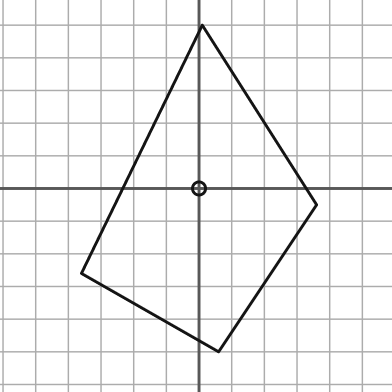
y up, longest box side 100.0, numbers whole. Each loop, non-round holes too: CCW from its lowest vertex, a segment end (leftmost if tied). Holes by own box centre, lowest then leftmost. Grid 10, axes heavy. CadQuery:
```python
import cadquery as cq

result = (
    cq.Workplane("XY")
    .moveTo(6.0, -50.0)
    .lineTo(36.0, -5.0)
    .lineTo(1.0, 50.0)
    .lineTo(-36.0, -26.0)
    .close()
    .moveTo(0.0, 0.0)
    .circle(2.0)
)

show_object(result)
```